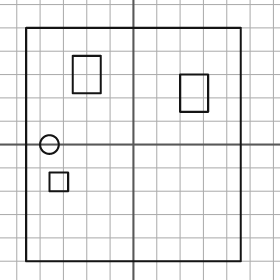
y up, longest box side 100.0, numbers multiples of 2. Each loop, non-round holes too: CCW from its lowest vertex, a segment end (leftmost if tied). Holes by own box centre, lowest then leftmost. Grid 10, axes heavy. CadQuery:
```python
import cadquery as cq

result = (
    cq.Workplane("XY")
    .moveTo(-46.0, -50.0)
    .lineTo(46.0, -50.0)
    .lineTo(46.0, 50.0)
    .lineTo(-46.0, 50.0)
    .close()
    .moveTo(-36.0, -20.0)
    .lineTo(-28.0, -20.0)
    .lineTo(-28.0, -12.0)
    .lineTo(-36.0, -12.0)
    .close()
    .moveTo(-36.0, 0.0)
    .circle(4.0)
    .moveTo(20.0, 14.0)
    .lineTo(32.0, 14.0)
    .lineTo(32.0, 30.0)
    .lineTo(20.0, 30.0)
    .close()
    .moveTo(-26.0, 22.0)
    .lineTo(-14.0, 22.0)
    .lineTo(-14.0, 38.0)
    .lineTo(-26.0, 38.0)
    .close()
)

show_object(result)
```